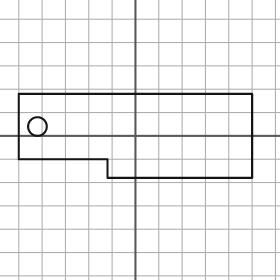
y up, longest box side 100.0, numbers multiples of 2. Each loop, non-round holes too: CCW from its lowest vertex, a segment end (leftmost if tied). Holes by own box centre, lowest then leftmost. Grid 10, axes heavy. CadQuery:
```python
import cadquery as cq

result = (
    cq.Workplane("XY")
    .moveTo(-12.0, -18.0)
    .lineTo(50.0, -18.0)
    .lineTo(50.0, 18.0)
    .lineTo(-50.0, 18.0)
    .lineTo(-50.0, -10.0)
    .lineTo(-12.0, -10.0)
    .close()
    .moveTo(-42.0, 4.0)
    .circle(4.0)
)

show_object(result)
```